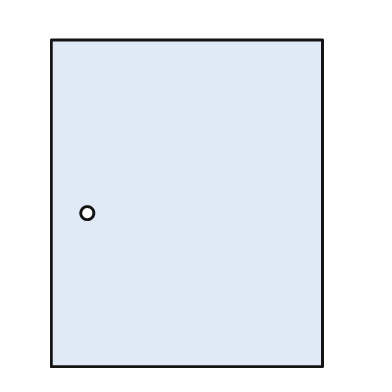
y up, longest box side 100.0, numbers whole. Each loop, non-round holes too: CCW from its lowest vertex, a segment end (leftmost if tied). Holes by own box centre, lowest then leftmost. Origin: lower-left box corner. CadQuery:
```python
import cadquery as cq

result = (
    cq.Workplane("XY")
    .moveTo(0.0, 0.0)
    .lineTo(83.0, 0.0)
    .lineTo(83.0, 100.0)
    .lineTo(0.0, 100.0)
    .close()
    .moveTo(11.0, 47.0)
    .circle(2.0)
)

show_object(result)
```